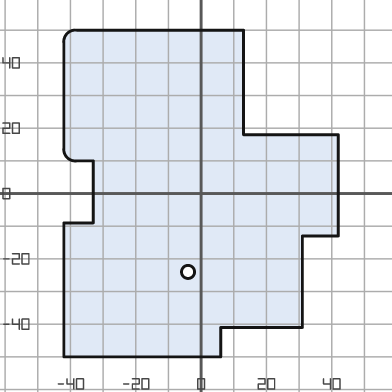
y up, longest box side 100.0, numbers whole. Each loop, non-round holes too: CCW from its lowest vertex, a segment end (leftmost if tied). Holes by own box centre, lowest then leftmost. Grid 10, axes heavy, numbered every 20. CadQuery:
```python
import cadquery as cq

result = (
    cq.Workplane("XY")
    .moveTo(-42.0, -50.0)
    .lineTo(6.0, -50.0)
    .lineTo(6.0, -41.0)
    .lineTo(31.0, -41.0)
    .lineTo(31.0, -13.0)
    .lineTo(42.0, -13.0)
    .lineTo(42.0, 18.0)
    .lineTo(13.0, 18.0)
    .lineTo(13.0, 50.0)
    .lineTo(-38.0, 50.0)
    .threePointArc((-41.0, 49.0), (-42.0, 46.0))
    .lineTo(-42.0, 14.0)
    .threePointArc((-41.0, 11.0), (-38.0, 10.0))
    .lineTo(-33.0, 10.0)
    .lineTo(-33.0, -9.0)
    .lineTo(-42.0, -9.0)
    .close()
    .moveTo(-4.0, -24.0)
    .circle(2.0)
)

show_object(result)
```